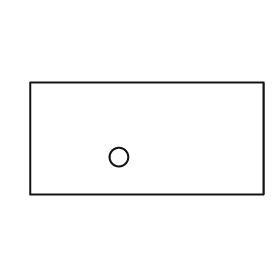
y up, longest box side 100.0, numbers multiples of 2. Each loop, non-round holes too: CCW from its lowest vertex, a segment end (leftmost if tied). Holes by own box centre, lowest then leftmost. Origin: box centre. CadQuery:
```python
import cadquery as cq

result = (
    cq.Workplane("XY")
    .moveTo(-50.0, -24.0)
    .lineTo(50.0, -24.0)
    .lineTo(50.0, 24.0)
    .lineTo(-50.0, 24.0)
    .close()
    .moveTo(-12.0, -8.0)
    .circle(4.0)
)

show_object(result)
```